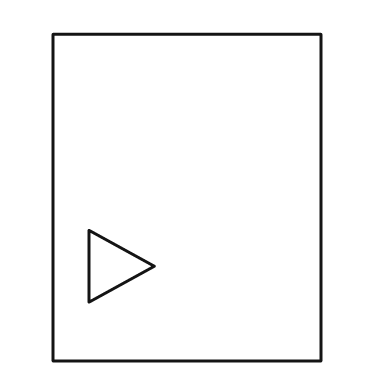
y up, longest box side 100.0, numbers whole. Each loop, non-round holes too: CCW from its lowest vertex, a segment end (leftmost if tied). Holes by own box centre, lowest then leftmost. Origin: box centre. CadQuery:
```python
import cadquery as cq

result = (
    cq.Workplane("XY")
    .moveTo(-41.0, -50.0)
    .lineTo(41.0, -50.0)
    .lineTo(41.0, 50.0)
    .lineTo(-41.0, 50.0)
    .close()
    .moveTo(-30.0, -32.0)
    .lineTo(-10.0, -21.0)
    .lineTo(-30.0, -10.0)
    .close()
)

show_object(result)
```